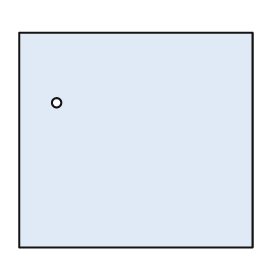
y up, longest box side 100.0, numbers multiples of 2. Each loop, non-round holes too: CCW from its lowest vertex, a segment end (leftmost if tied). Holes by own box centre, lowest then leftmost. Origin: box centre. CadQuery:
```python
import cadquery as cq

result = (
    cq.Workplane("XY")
    .moveTo(-50.0, -46.0)
    .lineTo(50.0, -46.0)
    .lineTo(50.0, 46.0)
    .lineTo(-50.0, 46.0)
    .close()
    .moveTo(-34.0, 16.0)
    .circle(2.0)
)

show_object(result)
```